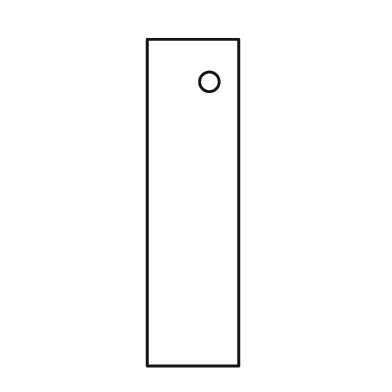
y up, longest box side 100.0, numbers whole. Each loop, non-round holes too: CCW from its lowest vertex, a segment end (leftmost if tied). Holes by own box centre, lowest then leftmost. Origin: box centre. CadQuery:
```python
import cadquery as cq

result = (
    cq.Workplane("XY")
    .moveTo(-14.0, -50.0)
    .lineTo(14.0, -50.0)
    .lineTo(14.0, 50.0)
    .lineTo(-14.0, 50.0)
    .close()
    .moveTo(5.0, 37.0)
    .circle(3.0)
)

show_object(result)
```